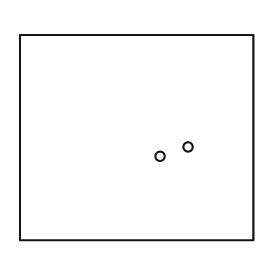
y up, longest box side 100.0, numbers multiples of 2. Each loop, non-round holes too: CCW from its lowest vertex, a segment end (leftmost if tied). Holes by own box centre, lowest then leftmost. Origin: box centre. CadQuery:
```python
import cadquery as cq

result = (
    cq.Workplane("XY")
    .moveTo(-50.0, -44.0)
    .lineTo(50.0, -44.0)
    .lineTo(50.0, 44.0)
    .lineTo(-50.0, 44.0)
    .close()
    .moveTo(10.0, -8.0)
    .circle(2.0)
    .moveTo(22.0, -4.0)
    .circle(2.0)
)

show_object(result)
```